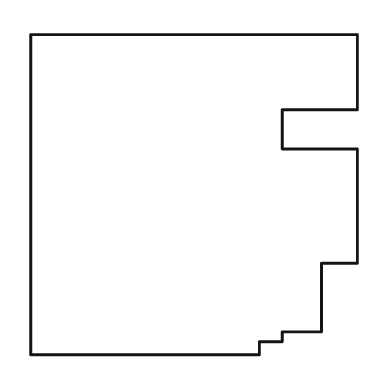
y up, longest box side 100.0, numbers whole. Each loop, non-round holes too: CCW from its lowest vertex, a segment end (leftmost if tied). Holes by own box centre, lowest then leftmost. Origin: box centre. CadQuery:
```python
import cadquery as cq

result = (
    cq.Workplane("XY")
    .moveTo(-50.0, -49.0)
    .lineTo(20.0, -49.0)
    .lineTo(20.0, -45.0)
    .lineTo(27.0, -45.0)
    .lineTo(27.0, -42.0)
    .lineTo(39.0, -42.0)
    .lineTo(39.0, -21.0)
    .lineTo(50.0, -21.0)
    .lineTo(50.0, 14.0)
    .lineTo(27.0, 14.0)
    .lineTo(27.0, 26.0)
    .lineTo(50.0, 26.0)
    .lineTo(50.0, 49.0)
    .lineTo(-50.0, 49.0)
    .close()
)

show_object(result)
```